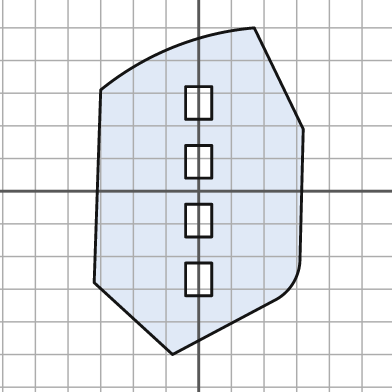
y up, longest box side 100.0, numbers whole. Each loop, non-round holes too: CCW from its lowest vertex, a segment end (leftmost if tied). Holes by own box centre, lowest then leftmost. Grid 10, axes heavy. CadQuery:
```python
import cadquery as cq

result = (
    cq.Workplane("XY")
    .moveTo(-8.0, -50.0)
    .lineTo(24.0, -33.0)
    .threePointArc((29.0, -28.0), (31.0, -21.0))
    .lineTo(32.0, 19.0)
    .lineTo(17.0, 50.0)
    .threePointArc((-8.0, 44.0), (-30.0, 31.0))
    .lineTo(-32.0, -28.0)
    .close()
    .moveTo(-4.0, -32.0)
    .lineTo(4.0, -32.0)
    .lineTo(4.0, -22.0)
    .lineTo(-4.0, -22.0)
    .close()
    .moveTo(-4.0, -14.0)
    .lineTo(4.0, -14.0)
    .lineTo(4.0, -4.0)
    .lineTo(-4.0, -4.0)
    .close()
    .moveTo(-4.0, 4.0)
    .lineTo(4.0, 4.0)
    .lineTo(4.0, 14.0)
    .lineTo(-4.0, 14.0)
    .close()
    .moveTo(-4.0, 22.0)
    .lineTo(4.0, 22.0)
    .lineTo(4.0, 32.0)
    .lineTo(-4.0, 32.0)
    .close()
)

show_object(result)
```